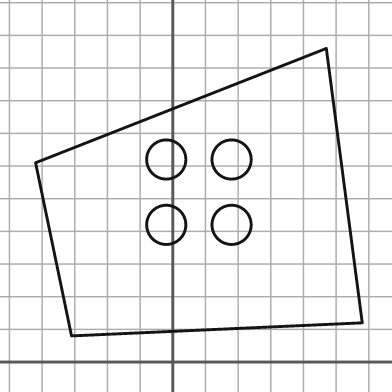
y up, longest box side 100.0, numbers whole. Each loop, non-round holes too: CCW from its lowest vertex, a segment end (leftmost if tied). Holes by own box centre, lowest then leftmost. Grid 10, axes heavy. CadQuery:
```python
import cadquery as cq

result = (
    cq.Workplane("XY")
    .moveTo(-31.0, 8.0)
    .lineTo(58.0, 12.0)
    .lineTo(47.0, 96.0)
    .lineTo(-42.0, 61.0)
    .close()
    .moveTo(-2.0, 42.0)
    .circle(6.0)
    .moveTo(18.0, 42.0)
    .circle(6.0)
    .moveTo(-2.0, 62.0)
    .circle(6.0)
    .moveTo(18.0, 62.0)
    .circle(6.0)
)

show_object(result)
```